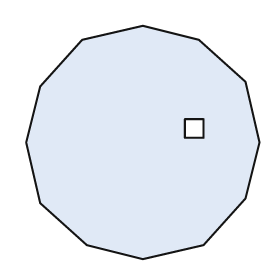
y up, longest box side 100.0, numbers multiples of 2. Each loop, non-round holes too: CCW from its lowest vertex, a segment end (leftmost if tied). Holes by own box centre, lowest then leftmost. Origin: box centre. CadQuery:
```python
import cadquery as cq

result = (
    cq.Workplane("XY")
    .moveTo(0.0, -50.0)
    .lineTo(26.0, -44.0)
    .lineTo(44.0, -24.0)
    .lineTo(50.0, 0.0)
    .lineTo(44.0, 26.0)
    .lineTo(24.0, 44.0)
    .lineTo(0.0, 50.0)
    .lineTo(-26.0, 44.0)
    .lineTo(-44.0, 24.0)
    .lineTo(-50.0, 0.0)
    .lineTo(-44.0, -26.0)
    .lineTo(-24.0, -44.0)
    .close()
    .moveTo(18.0, 2.0)
    .lineTo(26.0, 2.0)
    .lineTo(26.0, 10.0)
    .lineTo(18.0, 10.0)
    .close()
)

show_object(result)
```